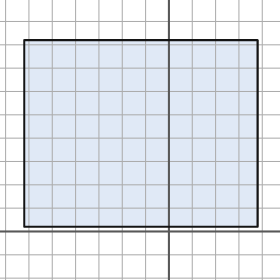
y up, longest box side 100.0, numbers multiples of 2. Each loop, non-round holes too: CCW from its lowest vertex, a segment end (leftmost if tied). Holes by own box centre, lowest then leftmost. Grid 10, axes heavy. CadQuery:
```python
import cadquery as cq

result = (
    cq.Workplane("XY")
    .moveTo(-62.0, 2.0)
    .lineTo(38.0, 2.0)
    .lineTo(38.0, 82.0)
    .lineTo(-62.0, 82.0)
    .close()
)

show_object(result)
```